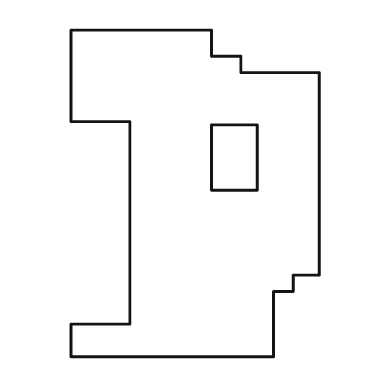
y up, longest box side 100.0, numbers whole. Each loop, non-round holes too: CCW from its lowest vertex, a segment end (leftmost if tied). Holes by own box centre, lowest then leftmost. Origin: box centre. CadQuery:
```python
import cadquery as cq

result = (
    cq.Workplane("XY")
    .moveTo(-38.0, -50.0)
    .lineTo(24.0, -50.0)
    .lineTo(24.0, -30.0)
    .lineTo(30.0, -30.0)
    .lineTo(30.0, -25.0)
    .lineTo(38.0, -25.0)
    .lineTo(38.0, 37.0)
    .lineTo(14.0, 37.0)
    .lineTo(14.0, 42.0)
    .lineTo(5.0, 42.0)
    .lineTo(5.0, 50.0)
    .lineTo(-38.0, 50.0)
    .lineTo(-38.0, 22.0)
    .lineTo(-20.0, 22.0)
    .lineTo(-20.0, -40.0)
    .lineTo(-38.0, -40.0)
    .close()
    .moveTo(5.0, 1.0)
    .lineTo(19.0, 1.0)
    .lineTo(19.0, 21.0)
    .lineTo(5.0, 21.0)
    .close()
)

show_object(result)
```